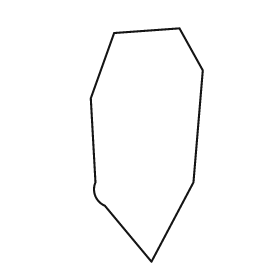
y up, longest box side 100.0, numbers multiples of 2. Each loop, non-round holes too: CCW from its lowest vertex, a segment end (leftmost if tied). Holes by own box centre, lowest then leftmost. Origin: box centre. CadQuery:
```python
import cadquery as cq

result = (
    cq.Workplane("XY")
    .moveTo(2.0, -50.0)
    .lineTo(20.0, -16.0)
    .lineTo(24.0, 32.0)
    .lineTo(14.0, 50.0)
    .lineTo(-14.0, 48.0)
    .lineTo(-24.0, 20.0)
    .lineTo(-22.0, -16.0)
    .threePointArc((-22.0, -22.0), (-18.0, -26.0))
    .close()
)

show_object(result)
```